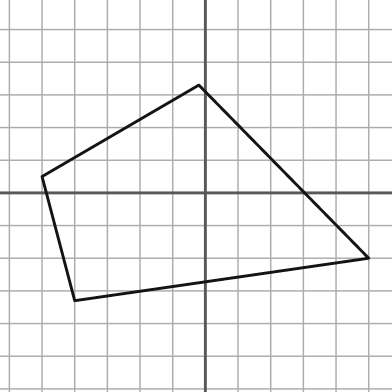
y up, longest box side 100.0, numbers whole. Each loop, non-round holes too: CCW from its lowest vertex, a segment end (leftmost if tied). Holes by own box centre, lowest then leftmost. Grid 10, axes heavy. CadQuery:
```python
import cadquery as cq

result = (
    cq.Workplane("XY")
    .moveTo(-40.0, -33.0)
    .lineTo(50.0, -20.0)
    .lineTo(-2.0, 33.0)
    .lineTo(-50.0, 5.0)
    .close()
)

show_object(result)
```